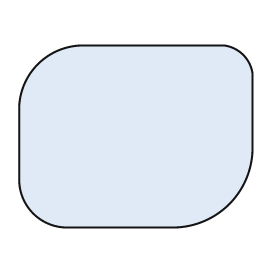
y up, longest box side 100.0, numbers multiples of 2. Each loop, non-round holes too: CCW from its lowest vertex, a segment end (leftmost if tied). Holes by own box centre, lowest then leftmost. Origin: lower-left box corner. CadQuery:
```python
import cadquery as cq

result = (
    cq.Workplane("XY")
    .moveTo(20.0, 0.0)
    .lineTo(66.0, 0.0)
    .threePointArc((90.0, 10.0), (100.0, 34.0))
    .lineTo(100.0, 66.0)
    .threePointArc((96.0, 74.0), (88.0, 78.0))
    .lineTo(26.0, 78.0)
    .threePointArc((8.0, 70.0), (0.0, 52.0))
    .lineTo(0.0, 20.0)
    .threePointArc((6.0, 6.0), (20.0, 0.0))
    .close()
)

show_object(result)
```